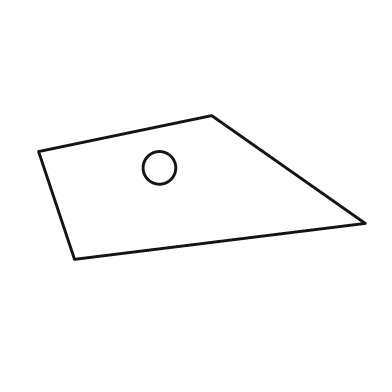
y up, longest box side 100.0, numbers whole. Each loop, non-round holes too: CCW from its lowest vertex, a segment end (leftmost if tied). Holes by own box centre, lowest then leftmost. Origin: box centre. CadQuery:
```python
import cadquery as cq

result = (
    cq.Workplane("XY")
    .moveTo(-39.0, -22.0)
    .lineTo(50.0, -11.0)
    .lineTo(3.0, 22.0)
    .lineTo(-50.0, 11.0)
    .close()
    .moveTo(-13.0, 6.0)
    .circle(5.0)
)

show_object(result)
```